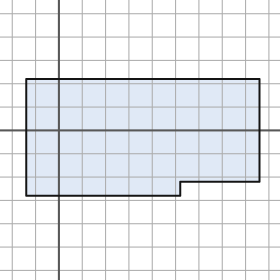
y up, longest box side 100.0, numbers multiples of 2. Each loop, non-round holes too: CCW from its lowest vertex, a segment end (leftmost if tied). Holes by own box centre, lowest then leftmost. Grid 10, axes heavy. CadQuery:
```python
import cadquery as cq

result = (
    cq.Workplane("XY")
    .moveTo(-14.0, -28.0)
    .lineTo(52.0, -28.0)
    .lineTo(52.0, -22.0)
    .lineTo(86.0, -22.0)
    .lineTo(86.0, 22.0)
    .lineTo(-14.0, 22.0)
    .close()
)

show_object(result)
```